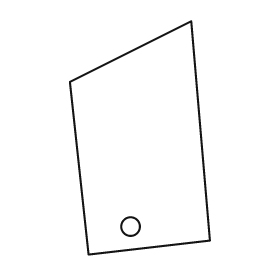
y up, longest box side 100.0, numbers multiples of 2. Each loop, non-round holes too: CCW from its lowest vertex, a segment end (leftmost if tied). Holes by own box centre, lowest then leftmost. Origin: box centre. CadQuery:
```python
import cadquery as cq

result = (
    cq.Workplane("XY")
    .moveTo(-22.0, -50.0)
    .lineTo(30.0, -44.0)
    .lineTo(22.0, 50.0)
    .lineTo(-30.0, 24.0)
    .close()
    .moveTo(-4.0, -38.0)
    .circle(4.0)
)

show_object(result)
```